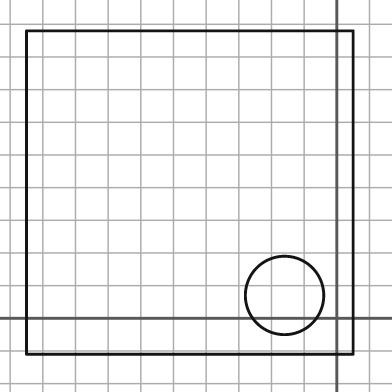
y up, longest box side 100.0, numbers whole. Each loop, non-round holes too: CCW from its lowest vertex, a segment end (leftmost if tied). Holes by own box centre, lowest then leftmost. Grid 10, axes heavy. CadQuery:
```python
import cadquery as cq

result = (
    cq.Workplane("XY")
    .moveTo(-95.0, -11.0)
    .lineTo(5.0, -11.0)
    .lineTo(5.0, 88.0)
    .lineTo(-95.0, 88.0)
    .close()
    .moveTo(-16.0, 7.0)
    .circle(12.0)
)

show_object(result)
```